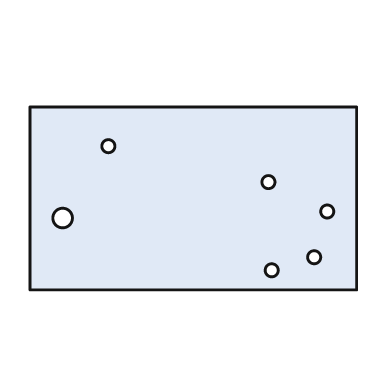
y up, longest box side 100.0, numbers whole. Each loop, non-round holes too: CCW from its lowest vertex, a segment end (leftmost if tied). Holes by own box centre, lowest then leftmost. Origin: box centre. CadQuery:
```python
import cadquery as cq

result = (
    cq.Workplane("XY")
    .moveTo(-50.0, -28.0)
    .lineTo(50.0, -28.0)
    .lineTo(50.0, 28.0)
    .lineTo(-50.0, 28.0)
    .close()
    .moveTo(24.0, -22.0)
    .circle(2.0)
    .moveTo(37.0, -18.0)
    .circle(2.0)
    .moveTo(-40.0, -6.0)
    .circle(3.0)
    .moveTo(41.0, -4.0)
    .circle(2.0)
    .moveTo(23.0, 5.0)
    .circle(2.0)
    .moveTo(-26.0, 16.0)
    .circle(2.0)
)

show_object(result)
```